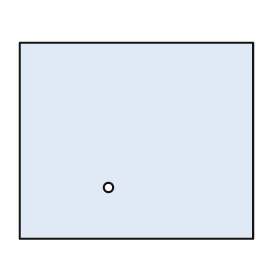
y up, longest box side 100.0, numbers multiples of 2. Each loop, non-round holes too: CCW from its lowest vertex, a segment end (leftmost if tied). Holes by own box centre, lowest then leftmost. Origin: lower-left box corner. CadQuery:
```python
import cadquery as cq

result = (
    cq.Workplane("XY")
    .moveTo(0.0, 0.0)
    .lineTo(100.0, 0.0)
    .lineTo(100.0, 84.0)
    .lineTo(0.0, 84.0)
    .close()
    .moveTo(38.0, 22.0)
    .circle(2.0)
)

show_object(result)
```